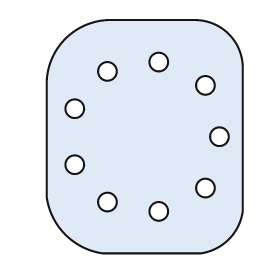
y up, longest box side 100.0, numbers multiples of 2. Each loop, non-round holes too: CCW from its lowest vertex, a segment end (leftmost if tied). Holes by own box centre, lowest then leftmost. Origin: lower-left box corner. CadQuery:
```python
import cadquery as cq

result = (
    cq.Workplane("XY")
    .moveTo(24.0, 0.0)
    .lineTo(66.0, 0.0)
    .threePointArc((78.0, 6.0), (84.0, 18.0))
    .lineTo(84.0, 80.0)
    .threePointArc((78.0, 94.0), (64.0, 100.0))
    .lineTo(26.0, 100.0)
    .threePointArc((8.0, 92.0), (0.0, 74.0))
    .lineTo(0.0, 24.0)
    .threePointArc((8.0, 8.0), (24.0, 0.0))
    .close()
    .moveTo(48.0, 18.0)
    .circle(4.0)
    .moveTo(26.0, 22.0)
    .circle(4.0)
    .moveTo(68.0, 28.0)
    .circle(4.0)
    .moveTo(12.0, 38.0)
    .circle(4.0)
    .moveTo(74.0, 50.0)
    .circle(4.0)
    .moveTo(12.0, 62.0)
    .circle(4.0)
    .moveTo(68.0, 72.0)
    .circle(4.0)
    .moveTo(26.0, 78.0)
    .circle(4.0)
    .moveTo(48.0, 82.0)
    .circle(4.0)
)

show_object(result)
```